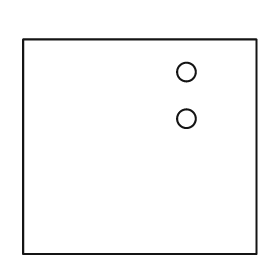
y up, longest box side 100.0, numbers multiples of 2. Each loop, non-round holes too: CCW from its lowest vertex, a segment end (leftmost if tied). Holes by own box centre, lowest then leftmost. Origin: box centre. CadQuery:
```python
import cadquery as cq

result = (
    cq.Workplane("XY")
    .moveTo(-50.0, -46.0)
    .lineTo(50.0, -46.0)
    .lineTo(50.0, 46.0)
    .lineTo(-50.0, 46.0)
    .close()
    .moveTo(20.0, 12.0)
    .circle(4.0)
    .moveTo(20.0, 32.0)
    .circle(4.0)
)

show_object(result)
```